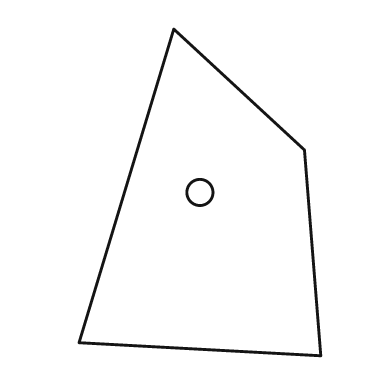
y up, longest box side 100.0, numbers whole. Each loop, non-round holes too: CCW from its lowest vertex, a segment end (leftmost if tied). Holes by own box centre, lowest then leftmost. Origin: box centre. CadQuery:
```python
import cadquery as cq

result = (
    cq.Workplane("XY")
    .moveTo(37.0, -50.0)
    .lineTo(32.0, 13.0)
    .lineTo(-8.0, 50.0)
    .lineTo(-37.0, -46.0)
    .close()
    .moveTo(0.0, 0.0)
    .circle(4.0)
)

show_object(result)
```